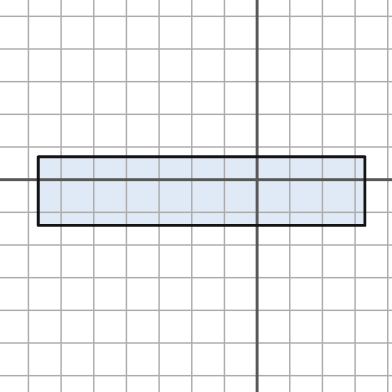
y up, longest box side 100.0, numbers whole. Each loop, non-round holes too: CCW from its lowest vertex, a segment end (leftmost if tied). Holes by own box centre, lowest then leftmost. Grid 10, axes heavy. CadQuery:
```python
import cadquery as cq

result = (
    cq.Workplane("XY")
    .moveTo(-67.0, -14.0)
    .lineTo(33.0, -14.0)
    .lineTo(33.0, 7.0)
    .lineTo(-67.0, 7.0)
    .close()
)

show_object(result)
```